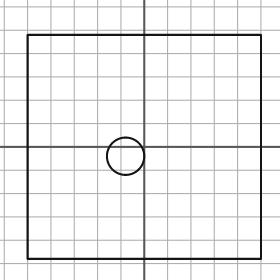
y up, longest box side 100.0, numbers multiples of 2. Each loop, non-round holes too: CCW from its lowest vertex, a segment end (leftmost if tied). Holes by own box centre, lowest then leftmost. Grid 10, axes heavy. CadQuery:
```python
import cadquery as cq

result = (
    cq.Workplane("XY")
    .moveTo(-50.0, -48.0)
    .lineTo(50.0, -48.0)
    .lineTo(50.0, 48.0)
    .lineTo(-50.0, 48.0)
    .close()
    .moveTo(-8.0, -4.0)
    .circle(8.0)
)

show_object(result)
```